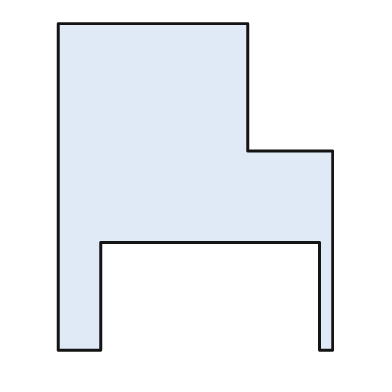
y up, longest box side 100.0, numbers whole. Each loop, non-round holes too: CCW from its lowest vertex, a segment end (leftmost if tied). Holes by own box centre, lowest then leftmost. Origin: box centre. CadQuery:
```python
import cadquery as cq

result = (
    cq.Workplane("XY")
    .moveTo(-42.0, -50.0)
    .lineTo(-29.0, -50.0)
    .lineTo(-29.0, -17.0)
    .lineTo(38.0, -17.0)
    .lineTo(38.0, -50.0)
    .lineTo(42.0, -50.0)
    .lineTo(42.0, 11.0)
    .lineTo(16.0, 11.0)
    .lineTo(16.0, 50.0)
    .lineTo(-42.0, 50.0)
    .close()
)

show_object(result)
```